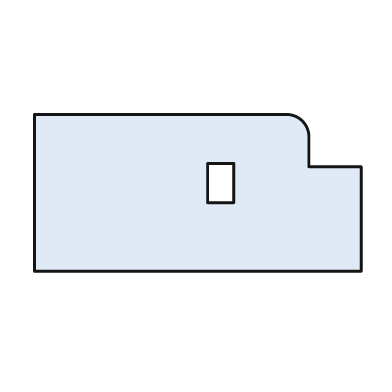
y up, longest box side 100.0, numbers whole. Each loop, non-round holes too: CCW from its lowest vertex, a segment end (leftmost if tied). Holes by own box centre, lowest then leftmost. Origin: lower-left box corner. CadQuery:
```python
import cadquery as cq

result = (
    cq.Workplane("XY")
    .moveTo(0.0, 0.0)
    .lineTo(100.0, 0.0)
    .lineTo(100.0, 32.0)
    .lineTo(84.0, 32.0)
    .lineTo(84.0, 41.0)
    .threePointArc((82.0, 46.0), (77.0, 48.0))
    .lineTo(0.0, 48.0)
    .close()
    .moveTo(53.0, 21.0)
    .lineTo(61.0, 21.0)
    .lineTo(61.0, 33.0)
    .lineTo(53.0, 33.0)
    .close()
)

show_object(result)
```